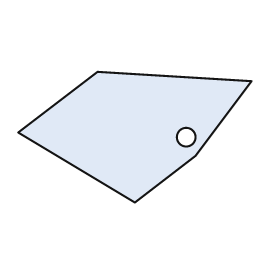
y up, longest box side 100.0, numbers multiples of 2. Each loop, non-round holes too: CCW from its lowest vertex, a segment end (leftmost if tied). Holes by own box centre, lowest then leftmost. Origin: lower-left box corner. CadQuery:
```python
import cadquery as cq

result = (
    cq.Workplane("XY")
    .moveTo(50.0, 0.0)
    .lineTo(76.0, 20.0)
    .lineTo(100.0, 52.0)
    .lineTo(34.0, 56.0)
    .lineTo(0.0, 30.0)
    .close()
    .moveTo(72.0, 28.0)
    .circle(4.0)
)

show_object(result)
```